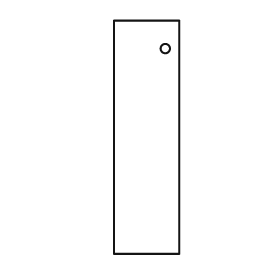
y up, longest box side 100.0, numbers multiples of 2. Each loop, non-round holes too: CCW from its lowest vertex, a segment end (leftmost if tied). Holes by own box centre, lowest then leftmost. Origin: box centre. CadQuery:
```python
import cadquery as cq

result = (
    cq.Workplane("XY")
    .moveTo(-14.0, -50.0)
    .lineTo(14.0, -50.0)
    .lineTo(14.0, 50.0)
    .lineTo(-14.0, 50.0)
    .close()
    .moveTo(8.0, 38.0)
    .circle(2.0)
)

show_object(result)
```